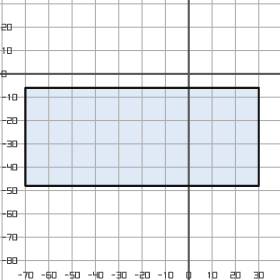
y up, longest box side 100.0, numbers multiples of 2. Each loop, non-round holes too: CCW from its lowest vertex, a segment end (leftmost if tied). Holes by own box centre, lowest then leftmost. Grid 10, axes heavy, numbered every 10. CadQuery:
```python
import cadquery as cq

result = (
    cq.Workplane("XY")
    .moveTo(-70.0, -48.0)
    .lineTo(30.0, -48.0)
    .lineTo(30.0, -6.0)
    .lineTo(-70.0, -6.0)
    .close()
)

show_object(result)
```